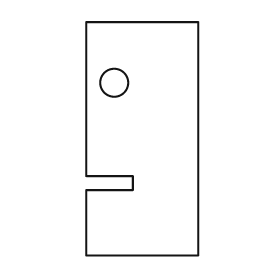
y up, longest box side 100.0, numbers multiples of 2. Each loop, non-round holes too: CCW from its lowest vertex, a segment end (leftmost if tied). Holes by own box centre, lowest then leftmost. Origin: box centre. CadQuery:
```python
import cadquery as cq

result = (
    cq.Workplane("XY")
    .moveTo(-24.0, -50.0)
    .lineTo(24.0, -50.0)
    .lineTo(24.0, 50.0)
    .lineTo(-24.0, 50.0)
    .lineTo(-24.0, -16.0)
    .lineTo(-4.0, -16.0)
    .lineTo(-4.0, -22.0)
    .lineTo(-24.0, -22.0)
    .close()
    .moveTo(-12.0, 24.0)
    .circle(6.0)
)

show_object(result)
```